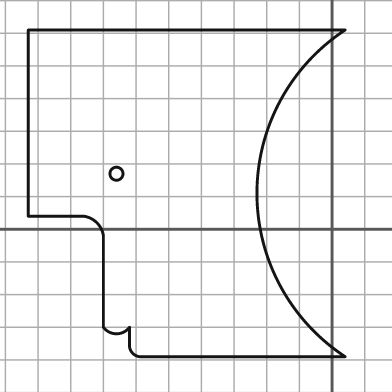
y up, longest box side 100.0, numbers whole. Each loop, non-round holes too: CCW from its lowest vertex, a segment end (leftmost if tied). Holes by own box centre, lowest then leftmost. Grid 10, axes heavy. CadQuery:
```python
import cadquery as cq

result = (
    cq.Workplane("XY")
    .moveTo(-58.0, -39.0)
    .lineTo(4.0, -39.0)
    .threePointArc((-23.0, 11.0), (4.0, 61.0))
    .lineTo(-93.0, 61.0)
    .lineTo(-93.0, 4.0)
    .lineTo(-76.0, 4.0)
    .threePointArc((-72.0, 2.0), (-70.0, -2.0))
    .lineTo(-70.0, -30.0)
    .threePointArc((-66.0, -32.0), (-62.0, -30.0))
    .lineTo(-62.0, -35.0)
    .threePointArc((-61.0, -38.0), (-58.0, -39.0))
    .close()
    .moveTo(-66.0, 17.0)
    .circle(2.0)
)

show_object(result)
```